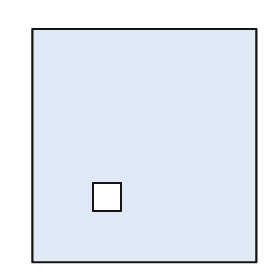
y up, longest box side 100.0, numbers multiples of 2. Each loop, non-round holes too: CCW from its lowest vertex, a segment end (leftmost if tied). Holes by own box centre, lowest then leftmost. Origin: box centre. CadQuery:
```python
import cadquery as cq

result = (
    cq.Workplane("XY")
    .moveTo(-48.0, -50.0)
    .lineTo(48.0, -50.0)
    .lineTo(48.0, 50.0)
    .lineTo(-48.0, 50.0)
    .close()
    .moveTo(-22.0, -28.0)
    .lineTo(-10.0, -28.0)
    .lineTo(-10.0, -16.0)
    .lineTo(-22.0, -16.0)
    .close()
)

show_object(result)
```